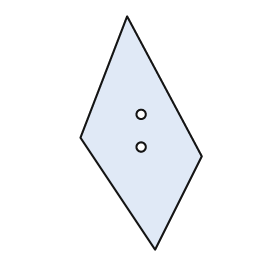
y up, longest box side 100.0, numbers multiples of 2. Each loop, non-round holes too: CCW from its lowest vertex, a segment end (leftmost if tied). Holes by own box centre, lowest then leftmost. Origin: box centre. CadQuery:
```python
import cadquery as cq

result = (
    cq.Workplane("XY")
    .moveTo(6.0, -50.0)
    .lineTo(26.0, -10.0)
    .lineTo(-6.0, 50.0)
    .lineTo(-26.0, -2.0)
    .close()
    .moveTo(0.0, -6.0)
    .circle(2.0)
    .moveTo(0.0, 8.0)
    .circle(2.0)
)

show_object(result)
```